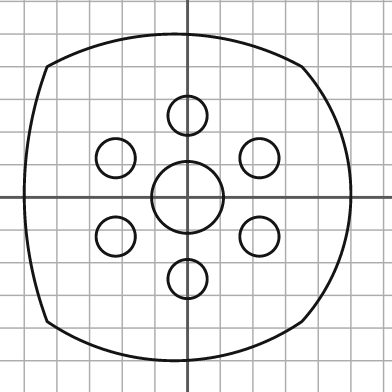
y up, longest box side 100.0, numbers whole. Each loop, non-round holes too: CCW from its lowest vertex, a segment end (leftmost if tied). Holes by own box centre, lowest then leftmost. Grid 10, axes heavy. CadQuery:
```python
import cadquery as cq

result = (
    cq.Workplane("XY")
    .moveTo(-43.0, -38.0)
    .threePointArc((-4.0, -50.0), (35.0, -38.0))
    .threePointArc((50.0, 1.0), (35.0, 40.0))
    .threePointArc((-4.0, 50.0), (-43.0, 40.0))
    .threePointArc((-50.0, 1.0), (-43.0, -38.0))
    .close()
    .moveTo(0.0, -25.0)
    .circle(6.0)
    .moveTo(-22.0, -12.0)
    .circle(6.0)
    .moveTo(22.0, -12.0)
    .circle(6.0)
    .moveTo(0.0, 0.0)
    .circle(11.0)
    .moveTo(-22.0, 12.0)
    .circle(6.0)
    .moveTo(22.0, 12.0)
    .circle(6.0)
    .moveTo(0.0, 25.0)
    .circle(6.0)
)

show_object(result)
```